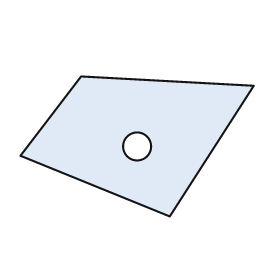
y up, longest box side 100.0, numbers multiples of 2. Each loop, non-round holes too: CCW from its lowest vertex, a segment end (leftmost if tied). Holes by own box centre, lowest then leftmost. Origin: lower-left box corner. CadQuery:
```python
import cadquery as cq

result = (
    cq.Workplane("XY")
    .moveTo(64.0, 0.0)
    .lineTo(100.0, 56.0)
    .lineTo(26.0, 60.0)
    .lineTo(0.0, 26.0)
    .close()
    .moveTo(50.0, 30.0)
    .circle(6.0)
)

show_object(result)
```